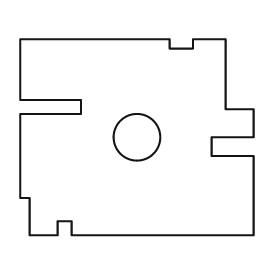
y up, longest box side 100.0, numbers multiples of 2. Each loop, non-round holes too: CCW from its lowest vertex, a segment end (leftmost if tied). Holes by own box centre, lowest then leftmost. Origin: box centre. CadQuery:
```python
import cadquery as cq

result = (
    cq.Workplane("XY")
    .moveTo(-46.0, -42.0)
    .lineTo(-34.0, -42.0)
    .lineTo(-34.0, -36.0)
    .lineTo(-28.0, -36.0)
    .lineTo(-28.0, -42.0)
    .lineTo(50.0, -42.0)
    .lineTo(50.0, -8.0)
    .lineTo(32.0, -8.0)
    .lineTo(32.0, 0.0)
    .lineTo(50.0, 0.0)
    .lineTo(50.0, 12.0)
    .lineTo(38.0, 12.0)
    .lineTo(38.0, 42.0)
    .lineTo(24.0, 42.0)
    .lineTo(24.0, 38.0)
    .lineTo(14.0, 38.0)
    .lineTo(14.0, 42.0)
    .lineTo(-50.0, 42.0)
    .lineTo(-50.0, 16.0)
    .lineTo(-24.0, 16.0)
    .lineTo(-24.0, 10.0)
    .lineTo(-50.0, 10.0)
    .lineTo(-50.0, -26.0)
    .lineTo(-46.0, -26.0)
    .close()
    .moveTo(0.0, 0.0)
    .circle(10.0)
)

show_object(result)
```